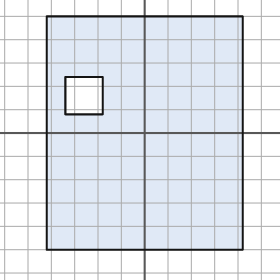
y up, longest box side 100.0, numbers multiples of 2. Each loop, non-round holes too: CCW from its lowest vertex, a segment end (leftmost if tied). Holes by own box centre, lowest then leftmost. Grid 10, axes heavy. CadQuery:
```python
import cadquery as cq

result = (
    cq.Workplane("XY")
    .moveTo(-42.0, -50.0)
    .lineTo(42.0, -50.0)
    .lineTo(42.0, 50.0)
    .lineTo(-42.0, 50.0)
    .close()
    .moveTo(-34.0, 8.0)
    .lineTo(-18.0, 8.0)
    .lineTo(-18.0, 24.0)
    .lineTo(-34.0, 24.0)
    .close()
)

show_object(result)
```